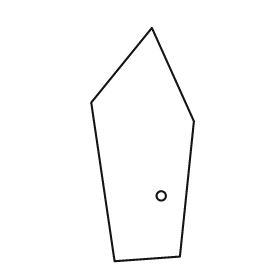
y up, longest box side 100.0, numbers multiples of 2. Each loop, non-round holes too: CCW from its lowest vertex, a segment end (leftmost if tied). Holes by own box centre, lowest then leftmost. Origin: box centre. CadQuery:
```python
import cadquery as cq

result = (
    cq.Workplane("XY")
    .moveTo(-12.0, -50.0)
    .lineTo(16.0, -48.0)
    .lineTo(22.0, 10.0)
    .lineTo(4.0, 50.0)
    .lineTo(-22.0, 18.0)
    .close()
    .moveTo(8.0, -22.0)
    .circle(2.0)
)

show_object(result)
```